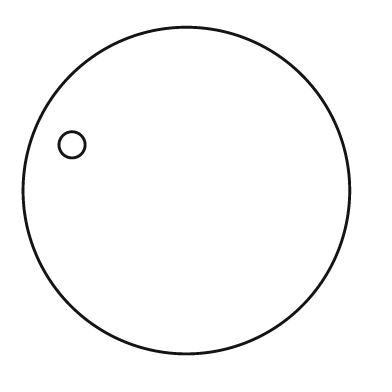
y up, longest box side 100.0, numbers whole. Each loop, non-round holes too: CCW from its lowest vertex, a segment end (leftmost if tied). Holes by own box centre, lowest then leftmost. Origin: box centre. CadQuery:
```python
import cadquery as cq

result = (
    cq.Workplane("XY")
    .moveTo(0.0, 0.0)
    .circle(50.0)
    .moveTo(-35.0, 14.0)
    .circle(4.0)
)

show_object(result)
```